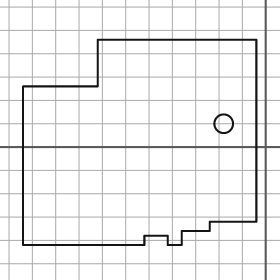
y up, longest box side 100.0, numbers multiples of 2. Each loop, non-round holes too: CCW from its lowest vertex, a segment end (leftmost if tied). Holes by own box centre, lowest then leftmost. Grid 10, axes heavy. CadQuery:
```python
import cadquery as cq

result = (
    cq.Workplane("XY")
    .moveTo(-104.0, -42.0)
    .lineTo(-52.0, -42.0)
    .lineTo(-52.0, -38.0)
    .lineTo(-42.0, -38.0)
    .lineTo(-42.0, -42.0)
    .lineTo(-36.0, -42.0)
    .lineTo(-36.0, -36.0)
    .lineTo(-24.0, -36.0)
    .lineTo(-24.0, -32.0)
    .lineTo(-4.0, -32.0)
    .lineTo(-4.0, 46.0)
    .lineTo(-72.0, 46.0)
    .lineTo(-72.0, 26.0)
    .lineTo(-104.0, 26.0)
    .close()
    .moveTo(-18.0, 10.0)
    .circle(4.0)
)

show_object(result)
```